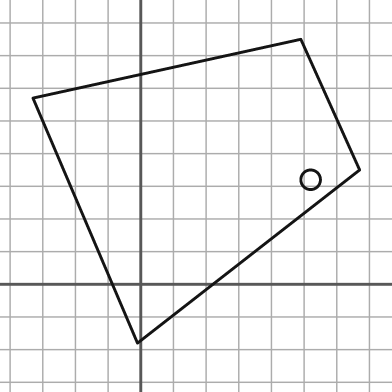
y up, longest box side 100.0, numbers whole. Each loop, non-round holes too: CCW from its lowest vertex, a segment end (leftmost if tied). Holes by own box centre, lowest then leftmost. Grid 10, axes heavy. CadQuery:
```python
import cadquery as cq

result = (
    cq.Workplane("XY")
    .moveTo(-1.0, -18.0)
    .lineTo(67.0, 35.0)
    .lineTo(49.0, 75.0)
    .lineTo(-33.0, 57.0)
    .close()
    .moveTo(52.0, 32.0)
    .circle(3.0)
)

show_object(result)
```